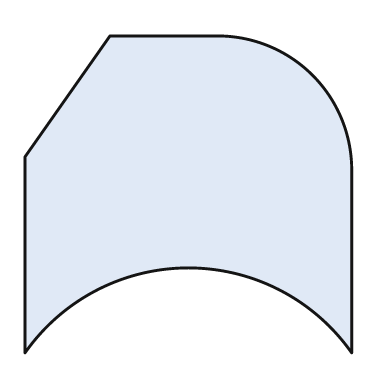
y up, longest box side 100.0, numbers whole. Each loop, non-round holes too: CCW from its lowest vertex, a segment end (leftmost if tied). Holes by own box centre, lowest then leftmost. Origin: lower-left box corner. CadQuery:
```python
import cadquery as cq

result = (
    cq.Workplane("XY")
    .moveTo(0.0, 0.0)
    .threePointArc((50.0, 26.0), (100.0, 0.0))
    .lineTo(100.0, 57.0)
    .threePointArc((88.0, 85.0), (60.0, 97.0))
    .lineTo(26.0, 97.0)
    .lineTo(0.0, 60.0)
    .close()
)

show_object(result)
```